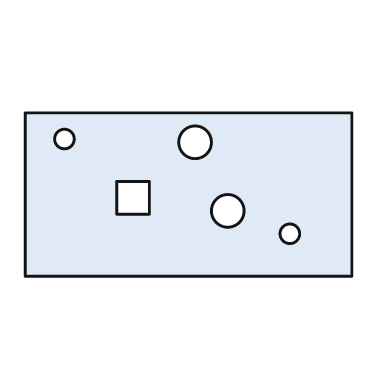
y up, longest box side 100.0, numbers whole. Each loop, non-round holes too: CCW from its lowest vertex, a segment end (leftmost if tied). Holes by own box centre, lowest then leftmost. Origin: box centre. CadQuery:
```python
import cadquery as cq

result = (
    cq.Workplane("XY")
    .moveTo(-50.0, -25.0)
    .lineTo(50.0, -25.0)
    .lineTo(50.0, 25.0)
    .lineTo(-50.0, 25.0)
    .close()
    .moveTo(31.0, -12.0)
    .circle(3.0)
    .moveTo(12.0, -5.0)
    .circle(5.0)
    .moveTo(-22.0, -6.0)
    .lineTo(-12.0, -6.0)
    .lineTo(-12.0, 4.0)
    .lineTo(-22.0, 4.0)
    .close()
    .moveTo(2.0, 16.0)
    .circle(5.0)
    .moveTo(-38.0, 17.0)
    .circle(3.0)
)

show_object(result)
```